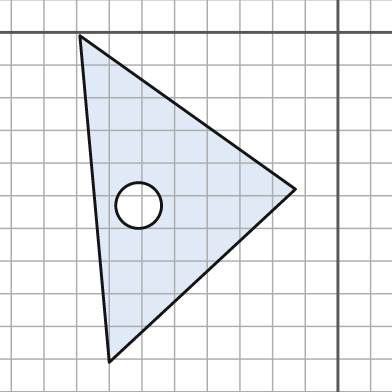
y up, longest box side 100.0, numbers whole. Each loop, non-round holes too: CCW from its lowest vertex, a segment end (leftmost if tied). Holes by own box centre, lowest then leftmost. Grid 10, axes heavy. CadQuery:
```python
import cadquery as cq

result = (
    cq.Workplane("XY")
    .moveTo(-70.0, -101.0)
    .lineTo(-13.0, -48.0)
    .lineTo(-79.0, -1.0)
    .close()
    .moveTo(-61.0, -53.0)
    .circle(7.0)
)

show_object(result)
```